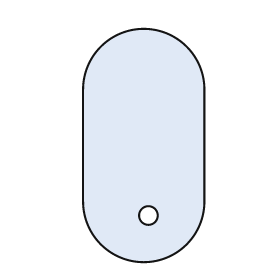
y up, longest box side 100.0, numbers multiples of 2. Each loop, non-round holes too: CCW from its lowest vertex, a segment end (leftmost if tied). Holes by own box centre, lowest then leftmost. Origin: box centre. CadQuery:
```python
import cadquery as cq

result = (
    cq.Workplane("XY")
    .moveTo(-26.0, -24.0)
    .threePointArc((0.0, -50.0), (26.0, -24.0))
    .lineTo(26.0, 24.0)
    .threePointArc((0.0, 50.0), (-26.0, 24.0))
    .close()
    .moveTo(2.0, -30.0)
    .circle(4.0)
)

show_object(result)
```